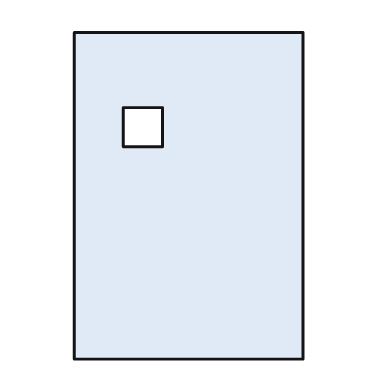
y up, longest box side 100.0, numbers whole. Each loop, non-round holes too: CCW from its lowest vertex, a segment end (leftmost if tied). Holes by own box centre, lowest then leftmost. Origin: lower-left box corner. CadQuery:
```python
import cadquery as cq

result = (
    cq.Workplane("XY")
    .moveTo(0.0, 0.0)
    .lineTo(70.0, 0.0)
    .lineTo(70.0, 100.0)
    .lineTo(0.0, 100.0)
    .close()
    .moveTo(15.0, 65.0)
    .lineTo(27.0, 65.0)
    .lineTo(27.0, 77.0)
    .lineTo(15.0, 77.0)
    .close()
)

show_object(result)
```